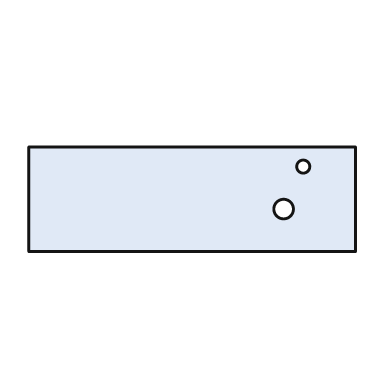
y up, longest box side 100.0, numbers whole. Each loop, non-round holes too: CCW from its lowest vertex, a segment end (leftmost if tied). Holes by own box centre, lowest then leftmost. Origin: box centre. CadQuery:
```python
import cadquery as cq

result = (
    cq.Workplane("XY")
    .moveTo(-50.0, -16.0)
    .lineTo(50.0, -16.0)
    .lineTo(50.0, 16.0)
    .lineTo(-50.0, 16.0)
    .close()
    .moveTo(28.0, -3.0)
    .circle(3.0)
    .moveTo(34.0, 10.0)
    .circle(2.0)
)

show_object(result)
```